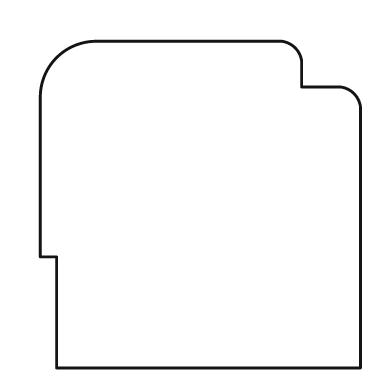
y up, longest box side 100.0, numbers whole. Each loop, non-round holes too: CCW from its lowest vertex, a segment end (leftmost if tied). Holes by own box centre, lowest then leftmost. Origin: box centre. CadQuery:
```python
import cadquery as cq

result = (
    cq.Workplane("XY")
    .moveTo(-44.0, -50.0)
    .lineTo(49.0, -50.0)
    .lineTo(49.0, 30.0)
    .threePointArc((47.0, 34.0), (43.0, 36.0))
    .lineTo(31.0, 36.0)
    .lineTo(31.0, 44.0)
    .threePointArc((29.0, 48.0), (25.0, 50.0))
    .lineTo(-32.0, 50.0)
    .threePointArc((-44.0, 45.0), (-49.0, 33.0))
    .lineTo(-49.0, -16.0)
    .lineTo(-44.0, -16.0)
    .close()
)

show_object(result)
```